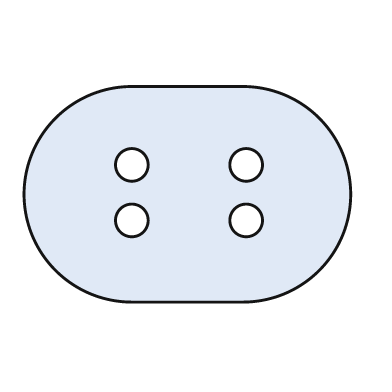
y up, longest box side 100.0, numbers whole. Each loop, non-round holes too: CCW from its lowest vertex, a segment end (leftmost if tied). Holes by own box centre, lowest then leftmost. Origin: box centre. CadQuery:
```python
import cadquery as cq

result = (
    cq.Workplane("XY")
    .moveTo(-17.0, -33.0)
    .lineTo(17.0, -33.0)
    .threePointArc((50.0, 0.0), (17.0, 33.0))
    .lineTo(-17.0, 33.0)
    .threePointArc((-50.0, 0.0), (-17.0, -33.0))
    .close()
    .moveTo(-17.0, -8.0)
    .circle(5.0)
    .moveTo(18.0, -8.0)
    .circle(5.0)
    .moveTo(-17.0, 9.0)
    .circle(5.0)
    .moveTo(18.0, 9.0)
    .circle(5.0)
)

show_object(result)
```